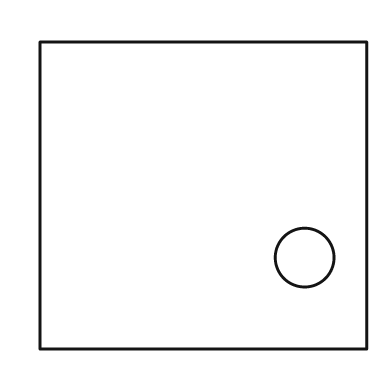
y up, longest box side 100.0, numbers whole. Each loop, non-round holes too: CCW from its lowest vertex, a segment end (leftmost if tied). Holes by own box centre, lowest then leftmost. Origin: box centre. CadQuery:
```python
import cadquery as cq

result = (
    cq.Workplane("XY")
    .moveTo(-50.0, -47.0)
    .lineTo(50.0, -47.0)
    .lineTo(50.0, 47.0)
    .lineTo(-50.0, 47.0)
    .close()
    .moveTo(31.0, -19.0)
    .circle(9.0)
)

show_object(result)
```